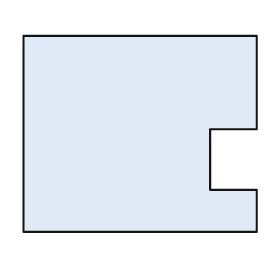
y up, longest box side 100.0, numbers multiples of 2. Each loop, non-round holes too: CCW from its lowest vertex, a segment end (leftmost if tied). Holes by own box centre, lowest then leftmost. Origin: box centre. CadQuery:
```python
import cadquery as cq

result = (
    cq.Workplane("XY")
    .moveTo(-50.0, -42.0)
    .lineTo(50.0, -42.0)
    .lineTo(50.0, -24.0)
    .lineTo(30.0, -24.0)
    .lineTo(30.0, 2.0)
    .lineTo(50.0, 2.0)
    .lineTo(50.0, 42.0)
    .lineTo(-50.0, 42.0)
    .close()
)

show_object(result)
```